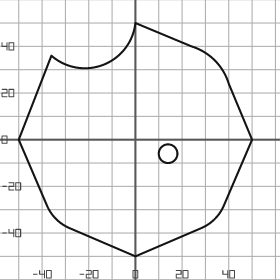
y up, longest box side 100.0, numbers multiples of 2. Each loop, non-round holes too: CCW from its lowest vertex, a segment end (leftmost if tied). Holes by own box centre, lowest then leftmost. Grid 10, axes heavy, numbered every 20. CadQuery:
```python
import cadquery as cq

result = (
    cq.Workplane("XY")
    .moveTo(0.0, -50.0)
    .lineTo(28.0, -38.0)
    .threePointArc((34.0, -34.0), (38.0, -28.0))
    .lineTo(50.0, 0.0)
    .lineTo(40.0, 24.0)
    .threePointArc((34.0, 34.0), (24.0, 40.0))
    .lineTo(0.0, 50.0)
    .threePointArc((-14.0, 32.0), (-36.0, 36.0))
    .lineTo(-50.0, 0.0)
    .lineTo(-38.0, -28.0)
    .threePointArc((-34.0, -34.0), (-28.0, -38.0))
    .close()
    .moveTo(14.0, -6.0)
    .circle(4.0)
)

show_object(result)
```